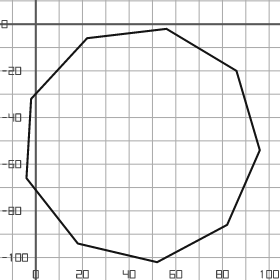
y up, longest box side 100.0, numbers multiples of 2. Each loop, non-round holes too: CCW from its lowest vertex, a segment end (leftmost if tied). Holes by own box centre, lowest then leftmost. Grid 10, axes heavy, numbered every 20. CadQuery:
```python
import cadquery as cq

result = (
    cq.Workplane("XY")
    .moveTo(52.0, -102.0)
    .lineTo(82.0, -86.0)
    .lineTo(96.0, -54.0)
    .lineTo(86.0, -20.0)
    .lineTo(56.0, -2.0)
    .lineTo(22.0, -6.0)
    .lineTo(-2.0, -32.0)
    .lineTo(-4.0, -66.0)
    .lineTo(18.0, -94.0)
    .close()
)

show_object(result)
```